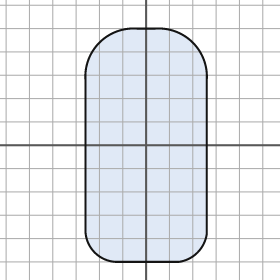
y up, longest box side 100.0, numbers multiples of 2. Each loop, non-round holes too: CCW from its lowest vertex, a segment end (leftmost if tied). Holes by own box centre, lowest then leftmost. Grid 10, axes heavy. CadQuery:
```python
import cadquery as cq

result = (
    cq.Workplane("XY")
    .moveTo(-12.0, -50.0)
    .lineTo(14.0, -50.0)
    .threePointArc((22.0, -46.0), (26.0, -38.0))
    .lineTo(26.0, 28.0)
    .threePointArc((20.0, 44.0), (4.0, 50.0))
    .lineTo(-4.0, 50.0)
    .threePointArc((-20.0, 44.0), (-26.0, 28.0))
    .lineTo(-26.0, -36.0)
    .threePointArc((-22.0, -46.0), (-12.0, -50.0))
    .close()
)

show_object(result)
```